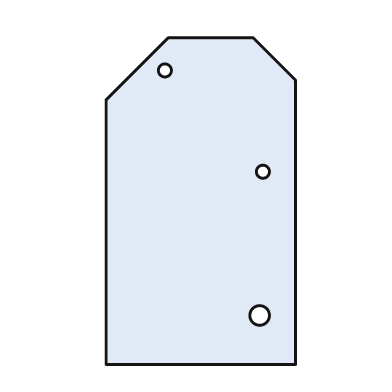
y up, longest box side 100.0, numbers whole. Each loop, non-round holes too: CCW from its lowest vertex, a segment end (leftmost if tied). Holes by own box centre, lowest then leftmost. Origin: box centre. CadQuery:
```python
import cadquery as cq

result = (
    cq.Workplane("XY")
    .moveTo(-29.0, -50.0)
    .lineTo(29.0, -50.0)
    .lineTo(29.0, 37.0)
    .lineTo(16.0, 50.0)
    .lineTo(-10.0, 50.0)
    .lineTo(-29.0, 31.0)
    .close()
    .moveTo(18.0, -35.0)
    .circle(3.0)
    .moveTo(19.0, 9.0)
    .circle(2.0)
    .moveTo(-11.0, 40.0)
    .circle(2.0)
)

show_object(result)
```